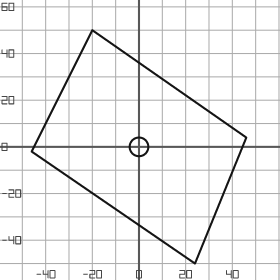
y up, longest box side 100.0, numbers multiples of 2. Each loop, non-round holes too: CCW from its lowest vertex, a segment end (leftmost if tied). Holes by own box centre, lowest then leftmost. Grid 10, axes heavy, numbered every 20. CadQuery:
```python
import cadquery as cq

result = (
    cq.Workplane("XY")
    .moveTo(24.0, -50.0)
    .lineTo(46.0, 4.0)
    .lineTo(-20.0, 50.0)
    .lineTo(-46.0, -2.0)
    .close()
    .moveTo(0.0, 0.0)
    .circle(4.0)
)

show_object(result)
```